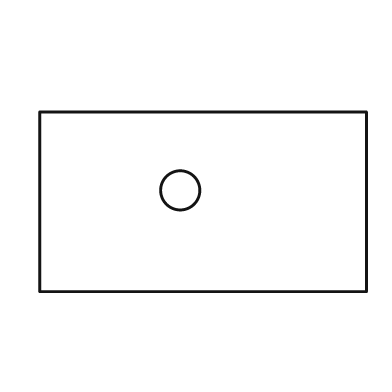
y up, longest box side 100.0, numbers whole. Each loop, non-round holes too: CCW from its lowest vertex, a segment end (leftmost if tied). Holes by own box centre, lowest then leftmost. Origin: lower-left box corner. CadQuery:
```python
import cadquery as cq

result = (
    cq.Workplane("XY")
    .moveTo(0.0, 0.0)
    .lineTo(100.0, 0.0)
    .lineTo(100.0, 55.0)
    .lineTo(0.0, 55.0)
    .close()
    .moveTo(43.0, 31.0)
    .circle(6.0)
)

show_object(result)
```